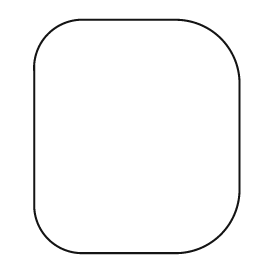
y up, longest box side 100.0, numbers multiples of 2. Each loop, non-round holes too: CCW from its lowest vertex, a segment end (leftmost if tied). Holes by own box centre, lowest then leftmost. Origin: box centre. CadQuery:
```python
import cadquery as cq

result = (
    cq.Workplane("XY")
    .moveTo(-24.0, -50.0)
    .lineTo(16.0, -50.0)
    .threePointArc((36.0, -42.0), (44.0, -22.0))
    .lineTo(44.0, 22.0)
    .threePointArc((36.0, 42.0), (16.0, 50.0))
    .lineTo(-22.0, 50.0)
    .threePointArc((-38.0, 44.0), (-44.0, 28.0))
    .lineTo(-44.0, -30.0)
    .threePointArc((-38.0, -44.0), (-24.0, -50.0))
    .close()
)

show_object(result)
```